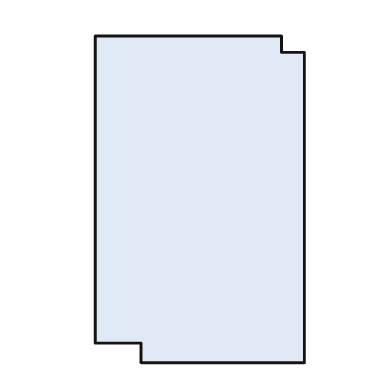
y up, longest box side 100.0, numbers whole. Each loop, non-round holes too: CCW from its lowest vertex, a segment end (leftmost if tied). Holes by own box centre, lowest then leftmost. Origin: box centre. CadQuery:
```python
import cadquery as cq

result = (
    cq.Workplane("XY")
    .moveTo(-18.0, -50.0)
    .lineTo(32.0, -50.0)
    .lineTo(32.0, 45.0)
    .lineTo(25.0, 45.0)
    .lineTo(25.0, 50.0)
    .lineTo(-32.0, 50.0)
    .lineTo(-32.0, -44.0)
    .lineTo(-18.0, -44.0)
    .close()
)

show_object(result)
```